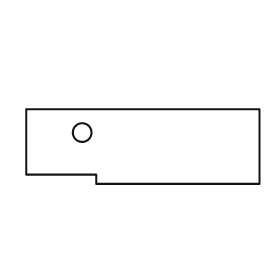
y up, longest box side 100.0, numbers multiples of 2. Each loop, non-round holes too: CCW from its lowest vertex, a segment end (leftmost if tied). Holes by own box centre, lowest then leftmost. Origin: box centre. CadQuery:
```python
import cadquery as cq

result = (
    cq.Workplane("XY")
    .moveTo(-20.0, -16.0)
    .lineTo(50.0, -16.0)
    .lineTo(50.0, 16.0)
    .lineTo(-50.0, 16.0)
    .lineTo(-50.0, -12.0)
    .lineTo(-20.0, -12.0)
    .close()
    .moveTo(-26.0, 6.0)
    .circle(4.0)
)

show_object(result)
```